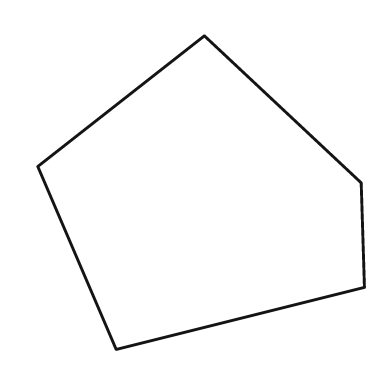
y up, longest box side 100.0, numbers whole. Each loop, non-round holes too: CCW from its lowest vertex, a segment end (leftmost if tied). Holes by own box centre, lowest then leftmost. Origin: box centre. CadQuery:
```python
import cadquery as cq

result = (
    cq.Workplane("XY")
    .moveTo(-26.0, -48.0)
    .lineTo(50.0, -29.0)
    .lineTo(49.0, 3.0)
    .lineTo(1.0, 48.0)
    .lineTo(-50.0, 8.0)
    .close()
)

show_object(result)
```